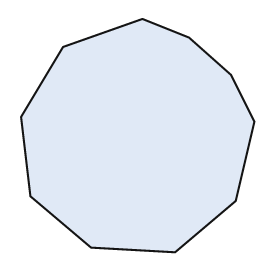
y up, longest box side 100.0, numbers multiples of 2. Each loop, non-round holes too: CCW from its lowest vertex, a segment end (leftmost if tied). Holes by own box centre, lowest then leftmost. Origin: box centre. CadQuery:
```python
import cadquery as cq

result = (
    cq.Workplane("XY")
    .moveTo(16.0, -50.0)
    .lineTo(42.0, -28.0)
    .lineTo(50.0, 6.0)
    .lineTo(40.0, 26.0)
    .lineTo(22.0, 42.0)
    .lineTo(2.0, 50.0)
    .lineTo(-32.0, 38.0)
    .lineTo(-50.0, 8.0)
    .lineTo(-46.0, -26.0)
    .lineTo(-20.0, -48.0)
    .close()
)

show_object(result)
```